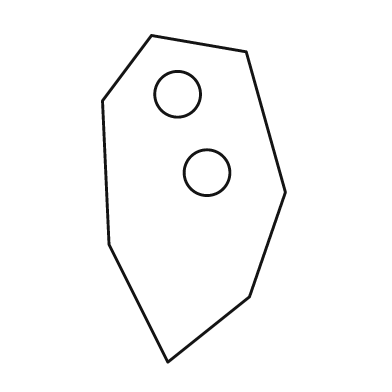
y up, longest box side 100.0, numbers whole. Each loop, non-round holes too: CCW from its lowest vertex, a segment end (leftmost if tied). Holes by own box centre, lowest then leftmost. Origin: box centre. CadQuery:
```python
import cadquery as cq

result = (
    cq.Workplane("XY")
    .moveTo(-8.0, -50.0)
    .lineTo(17.0, -30.0)
    .lineTo(28.0, 2.0)
    .lineTo(16.0, 45.0)
    .lineTo(-13.0, 50.0)
    .lineTo(-28.0, 30.0)
    .lineTo(-26.0, -14.0)
    .close()
    .moveTo(4.0, 8.0)
    .circle(7.0)
    .moveTo(-5.0, 32.0)
    .circle(7.0)
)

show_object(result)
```